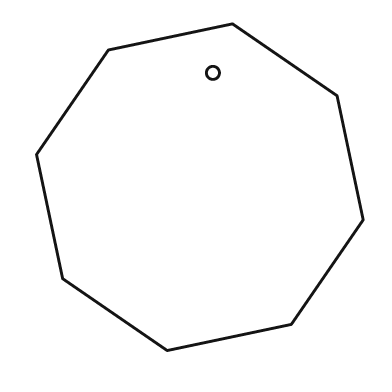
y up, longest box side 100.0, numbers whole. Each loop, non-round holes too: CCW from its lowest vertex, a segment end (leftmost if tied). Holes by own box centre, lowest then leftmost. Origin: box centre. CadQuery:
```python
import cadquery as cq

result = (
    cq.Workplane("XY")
    .moveTo(-10.0, -50.0)
    .lineTo(28.0, -42.0)
    .lineTo(50.0, -10.0)
    .lineTo(42.0, 28.0)
    .lineTo(10.0, 50.0)
    .lineTo(-28.0, 42.0)
    .lineTo(-50.0, 10.0)
    .lineTo(-42.0, -28.0)
    .close()
    .moveTo(4.0, 35.0)
    .circle(2.0)
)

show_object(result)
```